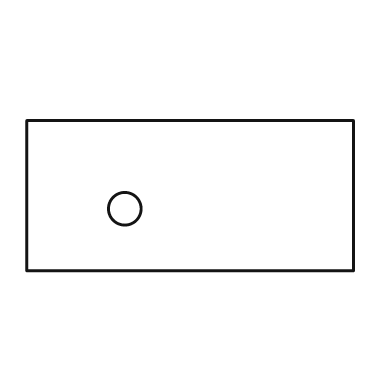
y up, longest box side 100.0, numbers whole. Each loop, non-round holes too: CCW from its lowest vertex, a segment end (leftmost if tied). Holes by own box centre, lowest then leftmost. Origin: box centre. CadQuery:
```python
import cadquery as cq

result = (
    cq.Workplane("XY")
    .moveTo(-50.0, -23.0)
    .lineTo(50.0, -23.0)
    .lineTo(50.0, 23.0)
    .lineTo(-50.0, 23.0)
    .close()
    .moveTo(-20.0, -4.0)
    .circle(5.0)
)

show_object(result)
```